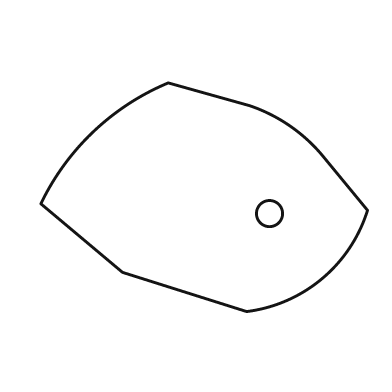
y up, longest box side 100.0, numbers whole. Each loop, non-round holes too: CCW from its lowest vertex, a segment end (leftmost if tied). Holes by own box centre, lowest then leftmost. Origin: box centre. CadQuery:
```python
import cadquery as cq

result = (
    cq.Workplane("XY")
    .moveTo(13.0, -35.0)
    .threePointArc((36.0, -25.0), (50.0, -4.0))
    .lineTo(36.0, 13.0)
    .threePointArc((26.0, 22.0), (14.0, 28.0))
    .lineTo(-11.0, 35.0)
    .threePointArc((-34.0, 20.0), (-50.0, -2.0))
    .lineTo(-25.0, -23.0)
    .close()
    .moveTo(20.0, -5.0)
    .circle(4.0)
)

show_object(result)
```